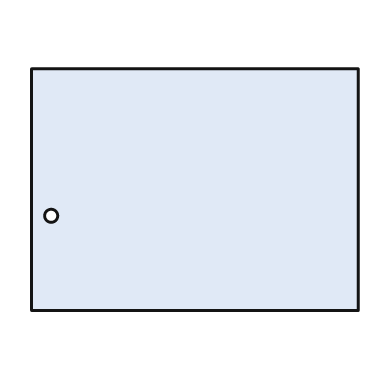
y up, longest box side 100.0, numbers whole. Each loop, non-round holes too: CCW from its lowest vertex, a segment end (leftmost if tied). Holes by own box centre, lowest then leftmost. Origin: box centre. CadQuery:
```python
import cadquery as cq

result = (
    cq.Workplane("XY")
    .moveTo(-50.0, -37.0)
    .lineTo(50.0, -37.0)
    .lineTo(50.0, 37.0)
    .lineTo(-50.0, 37.0)
    .close()
    .moveTo(-44.0, -8.0)
    .circle(2.0)
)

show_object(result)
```